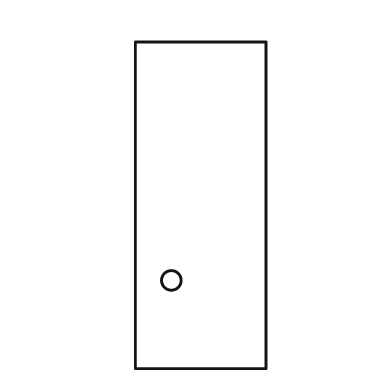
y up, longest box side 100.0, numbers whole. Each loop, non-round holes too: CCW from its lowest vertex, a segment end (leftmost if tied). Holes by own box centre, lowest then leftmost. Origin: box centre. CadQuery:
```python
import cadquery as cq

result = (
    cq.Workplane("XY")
    .moveTo(-20.0, -50.0)
    .lineTo(20.0, -50.0)
    .lineTo(20.0, 50.0)
    .lineTo(-20.0, 50.0)
    .close()
    .moveTo(-9.0, -23.0)
    .circle(3.0)
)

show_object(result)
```